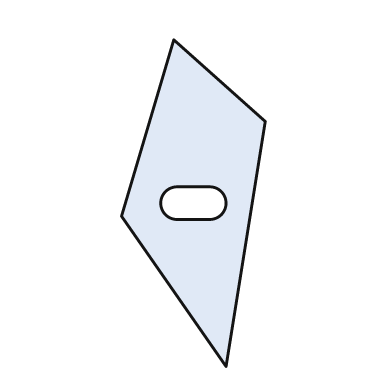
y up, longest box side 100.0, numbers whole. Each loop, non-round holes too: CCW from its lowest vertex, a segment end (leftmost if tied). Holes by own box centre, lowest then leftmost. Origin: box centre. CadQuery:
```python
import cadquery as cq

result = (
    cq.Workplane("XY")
    .moveTo(10.0, -50.0)
    .lineTo(22.0, 25.0)
    .lineTo(-6.0, 50.0)
    .lineTo(-22.0, -4.0)
    .close()
    .moveTo(-5.0, -5.0)
    .lineTo(5.0, -5.0)
    .threePointArc((10.0, 0.0), (5.0, 5.0))
    .lineTo(-5.0, 5.0)
    .threePointArc((-10.0, 0.0), (-5.0, -5.0))
    .close()
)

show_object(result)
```